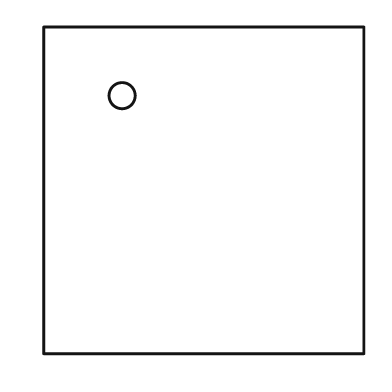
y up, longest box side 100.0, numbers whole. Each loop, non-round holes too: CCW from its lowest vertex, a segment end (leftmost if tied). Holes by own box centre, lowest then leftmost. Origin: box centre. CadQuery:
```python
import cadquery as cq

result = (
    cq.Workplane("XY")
    .moveTo(-49.0, -50.0)
    .lineTo(49.0, -50.0)
    .lineTo(49.0, 50.0)
    .lineTo(-49.0, 50.0)
    .close()
    .moveTo(-25.0, 29.0)
    .circle(4.0)
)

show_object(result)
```